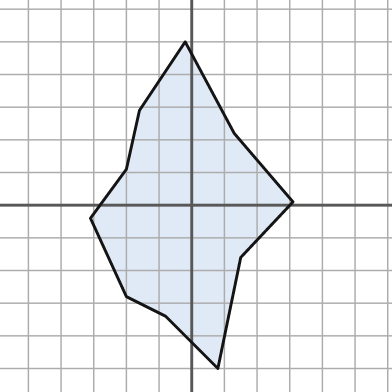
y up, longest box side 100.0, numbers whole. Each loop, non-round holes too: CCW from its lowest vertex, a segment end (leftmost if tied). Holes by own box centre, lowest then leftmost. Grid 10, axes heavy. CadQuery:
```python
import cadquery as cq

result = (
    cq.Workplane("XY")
    .moveTo(8.0, -50.0)
    .lineTo(15.0, -16.0)
    .lineTo(31.0, 1.0)
    .lineTo(13.0, 22.0)
    .lineTo(-2.0, 50.0)
    .lineTo(-16.0, 29.0)
    .lineTo(-20.0, 11.0)
    .lineTo(-31.0, -4.0)
    .lineTo(-20.0, -28.0)
    .lineTo(-8.0, -34.0)
    .close()
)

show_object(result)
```